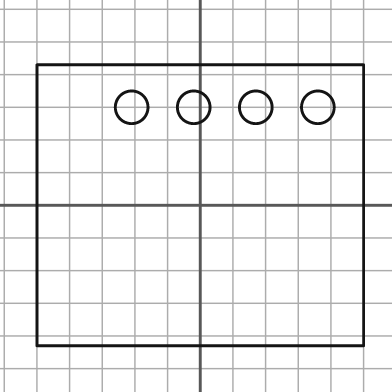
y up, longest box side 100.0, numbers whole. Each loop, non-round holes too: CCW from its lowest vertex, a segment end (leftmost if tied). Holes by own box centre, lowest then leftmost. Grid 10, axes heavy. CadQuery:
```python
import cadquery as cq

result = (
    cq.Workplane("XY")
    .moveTo(-50.0, -43.0)
    .lineTo(50.0, -43.0)
    .lineTo(50.0, 43.0)
    .lineTo(-50.0, 43.0)
    .close()
    .moveTo(-21.0, 30.0)
    .circle(5.0)
    .moveTo(-2.0, 30.0)
    .circle(5.0)
    .moveTo(17.0, 30.0)
    .circle(5.0)
    .moveTo(36.0, 30.0)
    .circle(5.0)
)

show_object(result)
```